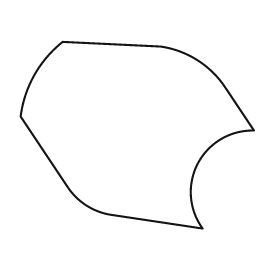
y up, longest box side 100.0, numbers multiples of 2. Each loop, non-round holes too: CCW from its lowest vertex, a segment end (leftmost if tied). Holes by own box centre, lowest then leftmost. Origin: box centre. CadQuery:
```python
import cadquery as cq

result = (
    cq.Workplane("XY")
    .moveTo(28.0, -40.0)
    .threePointArc((26.0, -12.0), (50.0, 2.0))
    .lineTo(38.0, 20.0)
    .threePointArc((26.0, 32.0), (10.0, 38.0))
    .lineTo(-32.0, 40.0)
    .threePointArc((-44.0, 26.0), (-50.0, 8.0))
    .lineTo(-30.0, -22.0)
    .threePointArc((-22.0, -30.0), (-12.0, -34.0))
    .close()
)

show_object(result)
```